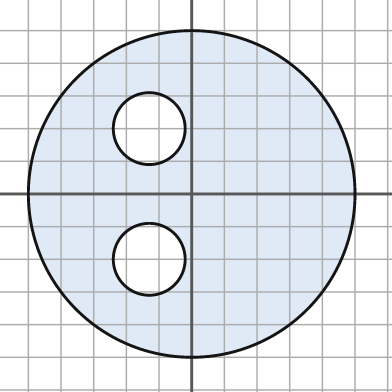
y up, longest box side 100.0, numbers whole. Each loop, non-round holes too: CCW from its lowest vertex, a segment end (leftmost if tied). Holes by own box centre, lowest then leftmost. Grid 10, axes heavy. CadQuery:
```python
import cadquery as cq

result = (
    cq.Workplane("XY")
    .moveTo(0.0, 0.0)
    .circle(50.0)
    .moveTo(-13.0, -20.0)
    .circle(11.0)
    .moveTo(-13.0, 20.0)
    .circle(11.0)
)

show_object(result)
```